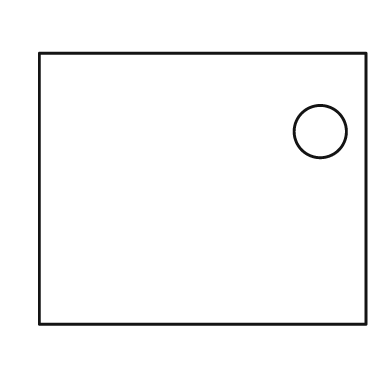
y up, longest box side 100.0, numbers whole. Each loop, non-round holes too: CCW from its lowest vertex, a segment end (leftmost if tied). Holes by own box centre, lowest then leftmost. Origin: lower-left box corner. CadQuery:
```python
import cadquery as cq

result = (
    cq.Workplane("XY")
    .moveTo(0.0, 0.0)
    .lineTo(100.0, 0.0)
    .lineTo(100.0, 83.0)
    .lineTo(0.0, 83.0)
    .close()
    .moveTo(86.0, 59.0)
    .circle(8.0)
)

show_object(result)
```